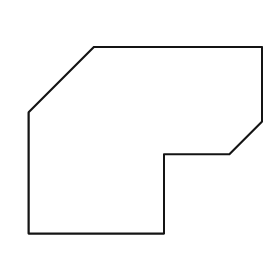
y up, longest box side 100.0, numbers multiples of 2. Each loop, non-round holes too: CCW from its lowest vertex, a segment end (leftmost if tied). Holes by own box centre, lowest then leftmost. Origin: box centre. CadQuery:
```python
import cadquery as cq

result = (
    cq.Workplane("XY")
    .moveTo(-50.0, -40.0)
    .lineTo(8.0, -40.0)
    .lineTo(8.0, -6.0)
    .lineTo(36.0, -6.0)
    .lineTo(50.0, 8.0)
    .lineTo(50.0, 40.0)
    .lineTo(-22.0, 40.0)
    .lineTo(-50.0, 12.0)
    .close()
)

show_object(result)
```